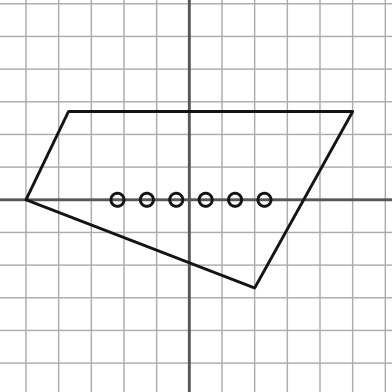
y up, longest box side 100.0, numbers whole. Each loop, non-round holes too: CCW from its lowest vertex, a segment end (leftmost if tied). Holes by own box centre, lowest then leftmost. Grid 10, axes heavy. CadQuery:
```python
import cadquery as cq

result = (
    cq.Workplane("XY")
    .moveTo(20.0, -27.0)
    .lineTo(50.0, 27.0)
    .lineTo(-37.0, 27.0)
    .lineTo(-50.0, 0.0)
    .close()
    .moveTo(-22.0, 0.0)
    .circle(2.0)
    .moveTo(-13.0, 0.0)
    .circle(2.0)
    .moveTo(-4.0, 0.0)
    .circle(2.0)
    .moveTo(5.0, 0.0)
    .circle(2.0)
    .moveTo(14.0, 0.0)
    .circle(2.0)
    .moveTo(23.0, 0.0)
    .circle(2.0)
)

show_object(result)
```